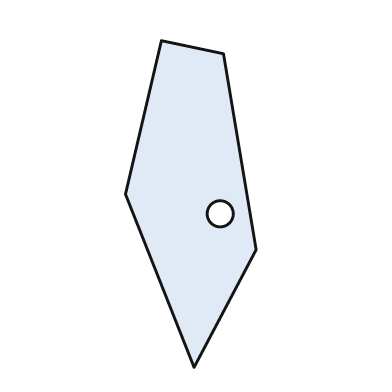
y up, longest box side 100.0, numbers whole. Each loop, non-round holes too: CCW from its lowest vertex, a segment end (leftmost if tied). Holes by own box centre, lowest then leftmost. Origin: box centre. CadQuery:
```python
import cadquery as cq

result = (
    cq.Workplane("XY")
    .moveTo(1.0, -50.0)
    .lineTo(20.0, -14.0)
    .lineTo(10.0, 46.0)
    .lineTo(-9.0, 50.0)
    .lineTo(-20.0, 3.0)
    .close()
    .moveTo(9.0, -3.0)
    .circle(4.0)
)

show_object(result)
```